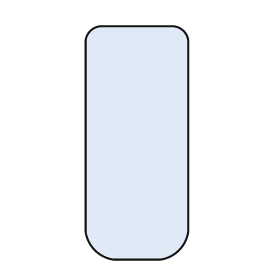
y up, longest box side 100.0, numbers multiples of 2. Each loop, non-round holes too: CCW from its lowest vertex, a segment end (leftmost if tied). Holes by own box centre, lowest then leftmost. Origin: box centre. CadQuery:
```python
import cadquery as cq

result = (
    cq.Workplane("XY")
    .moveTo(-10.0, -50.0)
    .lineTo(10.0, -50.0)
    .threePointArc((18.0, -46.0), (22.0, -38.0))
    .lineTo(22.0, 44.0)
    .threePointArc((20.0, 48.0), (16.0, 50.0))
    .lineTo(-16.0, 50.0)
    .threePointArc((-20.0, 48.0), (-22.0, 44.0))
    .lineTo(-22.0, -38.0)
    .threePointArc((-18.0, -46.0), (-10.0, -50.0))
    .close()
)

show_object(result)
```